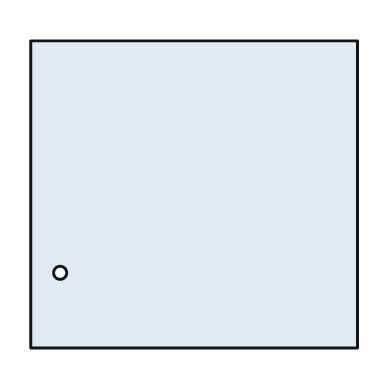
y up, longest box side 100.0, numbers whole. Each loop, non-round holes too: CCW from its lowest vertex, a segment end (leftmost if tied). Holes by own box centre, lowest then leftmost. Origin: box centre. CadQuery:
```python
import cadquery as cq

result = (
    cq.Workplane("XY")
    .moveTo(-50.0, -47.0)
    .lineTo(50.0, -47.0)
    .lineTo(50.0, 47.0)
    .lineTo(-50.0, 47.0)
    .close()
    .moveTo(-41.0, -24.0)
    .circle(2.0)
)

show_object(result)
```